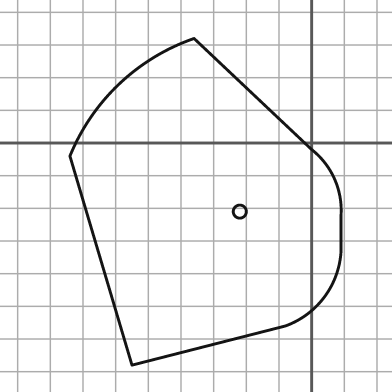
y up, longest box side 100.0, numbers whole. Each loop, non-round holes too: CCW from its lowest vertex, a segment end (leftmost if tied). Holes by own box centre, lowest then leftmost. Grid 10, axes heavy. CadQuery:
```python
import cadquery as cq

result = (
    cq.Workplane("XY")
    .moveTo(-55.0, -68.0)
    .lineTo(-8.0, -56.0)
    .threePointArc((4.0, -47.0), (9.0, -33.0))
    .lineTo(9.0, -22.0)
    .threePointArc((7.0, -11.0), (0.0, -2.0))
    .lineTo(-36.0, 32.0)
    .threePointArc((-59.0, 18.0), (-74.0, -4.0))
    .close()
    .moveTo(-22.0, -21.0)
    .circle(2.0)
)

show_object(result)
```